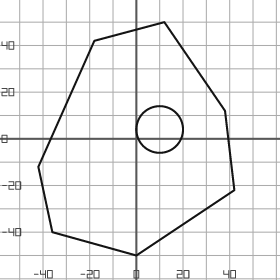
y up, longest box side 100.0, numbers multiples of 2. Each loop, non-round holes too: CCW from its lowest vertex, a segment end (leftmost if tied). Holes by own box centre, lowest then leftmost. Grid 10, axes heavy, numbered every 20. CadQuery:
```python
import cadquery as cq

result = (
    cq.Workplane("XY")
    .moveTo(0.0, -50.0)
    .lineTo(42.0, -22.0)
    .lineTo(38.0, 12.0)
    .lineTo(12.0, 50.0)
    .lineTo(-18.0, 42.0)
    .lineTo(-42.0, -12.0)
    .lineTo(-36.0, -40.0)
    .close()
    .moveTo(10.0, 4.0)
    .circle(10.0)
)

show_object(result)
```